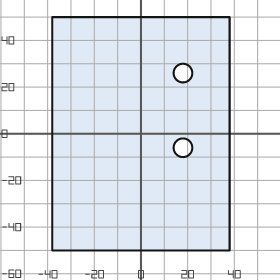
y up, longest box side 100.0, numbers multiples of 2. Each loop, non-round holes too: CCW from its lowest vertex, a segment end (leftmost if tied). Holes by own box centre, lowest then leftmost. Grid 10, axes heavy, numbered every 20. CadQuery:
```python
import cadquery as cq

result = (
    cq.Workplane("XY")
    .moveTo(-38.0, -50.0)
    .lineTo(38.0, -50.0)
    .lineTo(38.0, 50.0)
    .lineTo(-38.0, 50.0)
    .close()
    .moveTo(18.0, -6.0)
    .circle(4.0)
    .moveTo(18.0, 26.0)
    .circle(4.0)
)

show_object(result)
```